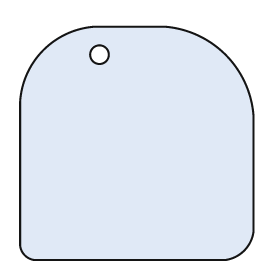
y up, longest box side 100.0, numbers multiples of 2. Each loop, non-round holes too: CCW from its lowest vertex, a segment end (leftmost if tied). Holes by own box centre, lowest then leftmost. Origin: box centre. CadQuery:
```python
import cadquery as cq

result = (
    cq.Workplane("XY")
    .moveTo(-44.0, -50.0)
    .lineTo(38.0, -50.0)
    .threePointArc((46.0, -46.0), (50.0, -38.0))
    .lineTo(50.0, 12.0)
    .threePointArc((38.0, 38.0), (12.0, 50.0))
    .lineTo(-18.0, 50.0)
    .threePointArc((-40.0, 40.0), (-50.0, 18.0))
    .lineTo(-50.0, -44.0)
    .threePointArc((-48.0, -48.0), (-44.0, -50.0))
    .close()
    .moveTo(-16.0, 38.0)
    .circle(4.0)
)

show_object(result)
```